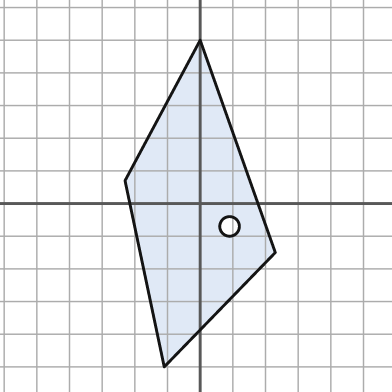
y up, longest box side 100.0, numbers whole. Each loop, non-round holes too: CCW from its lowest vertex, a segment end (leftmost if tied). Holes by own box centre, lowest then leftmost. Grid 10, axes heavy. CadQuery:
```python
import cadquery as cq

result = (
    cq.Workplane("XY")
    .moveTo(-11.0, -50.0)
    .lineTo(23.0, -15.0)
    .lineTo(0.0, 50.0)
    .lineTo(-23.0, 7.0)
    .close()
    .moveTo(9.0, -7.0)
    .circle(3.0)
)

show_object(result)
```